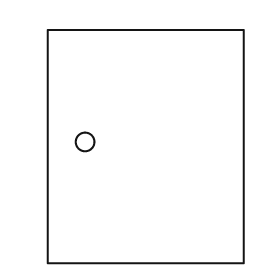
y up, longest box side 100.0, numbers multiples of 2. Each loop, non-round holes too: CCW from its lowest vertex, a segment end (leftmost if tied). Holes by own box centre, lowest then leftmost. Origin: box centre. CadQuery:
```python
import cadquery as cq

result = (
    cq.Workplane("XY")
    .moveTo(-42.0, -50.0)
    .lineTo(42.0, -50.0)
    .lineTo(42.0, 50.0)
    .lineTo(-42.0, 50.0)
    .close()
    .moveTo(-26.0, 2.0)
    .circle(4.0)
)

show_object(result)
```